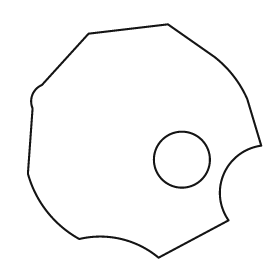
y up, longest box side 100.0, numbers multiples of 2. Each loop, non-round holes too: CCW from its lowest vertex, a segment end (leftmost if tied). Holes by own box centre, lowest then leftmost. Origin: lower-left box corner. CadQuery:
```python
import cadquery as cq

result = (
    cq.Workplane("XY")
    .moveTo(56.0, 0.0)
    .lineTo(86.0, 16.0)
    .threePointArc((84.0, 36.0), (100.0, 48.0))
    .lineTo(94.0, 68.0)
    .threePointArc((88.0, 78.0), (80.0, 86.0))
    .lineTo(60.0, 100.0)
    .lineTo(26.0, 96.0)
    .lineTo(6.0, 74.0)
    .threePointArc((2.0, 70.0), (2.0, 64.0))
    .lineTo(0.0, 36.0)
    .threePointArc((8.0, 20.0), (22.0, 8.0))
    .threePointArc((40.0, 8.0), (56.0, 0.0))
    .close()
    .moveTo(66.0, 42.0)
    .circle(12.0)
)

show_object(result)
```